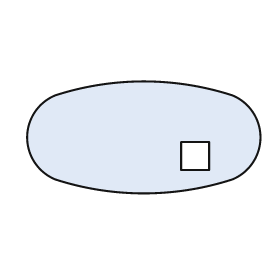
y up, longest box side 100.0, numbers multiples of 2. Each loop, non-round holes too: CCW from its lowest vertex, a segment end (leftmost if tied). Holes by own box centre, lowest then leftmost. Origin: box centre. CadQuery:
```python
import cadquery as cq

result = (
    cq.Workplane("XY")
    .moveTo(-38.0, -18.0)
    .threePointArc((0.0, -24.0), (38.0, -18.0))
    .threePointArc((50.0, 0.0), (38.0, 18.0))
    .threePointArc((0.0, 24.0), (-38.0, 18.0))
    .threePointArc((-50.0, 0.0), (-38.0, -18.0))
    .close()
    .moveTo(16.0, -14.0)
    .lineTo(28.0, -14.0)
    .lineTo(28.0, -2.0)
    .lineTo(16.0, -2.0)
    .close()
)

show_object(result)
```